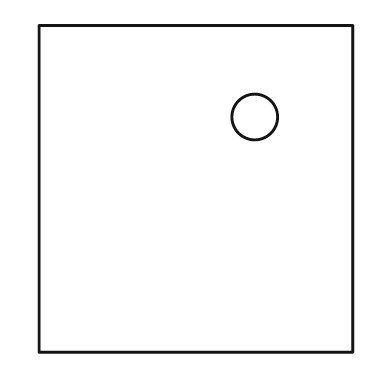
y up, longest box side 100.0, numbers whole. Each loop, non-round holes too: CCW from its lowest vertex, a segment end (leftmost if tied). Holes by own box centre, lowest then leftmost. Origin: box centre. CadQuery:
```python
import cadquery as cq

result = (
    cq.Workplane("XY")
    .moveTo(-48.0, -50.0)
    .lineTo(48.0, -50.0)
    .lineTo(48.0, 50.0)
    .lineTo(-48.0, 50.0)
    .close()
    .moveTo(18.0, 22.0)
    .circle(7.0)
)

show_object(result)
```